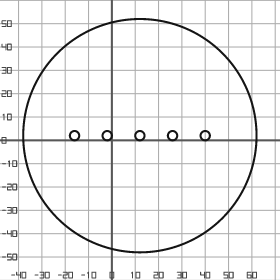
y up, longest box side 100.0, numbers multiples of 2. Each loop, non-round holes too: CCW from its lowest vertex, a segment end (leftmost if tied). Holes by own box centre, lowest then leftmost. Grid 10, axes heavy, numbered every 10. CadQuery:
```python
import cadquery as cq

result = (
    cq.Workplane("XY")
    .moveTo(12.0, 2.0)
    .circle(50.0)
    .moveTo(-16.0, 2.0)
    .circle(2.0)
    .moveTo(-2.0, 2.0)
    .circle(2.0)
    .moveTo(12.0, 2.0)
    .circle(2.0)
    .moveTo(26.0, 2.0)
    .circle(2.0)
    .moveTo(40.0, 2.0)
    .circle(2.0)
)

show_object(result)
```